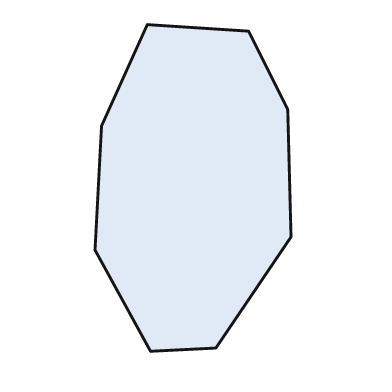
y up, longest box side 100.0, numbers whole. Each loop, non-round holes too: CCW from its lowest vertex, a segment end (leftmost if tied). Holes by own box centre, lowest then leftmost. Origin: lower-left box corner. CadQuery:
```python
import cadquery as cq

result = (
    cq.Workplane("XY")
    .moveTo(17.0, 0.0)
    .lineTo(37.0, 1.0)
    .lineTo(60.0, 35.0)
    .lineTo(59.0, 74.0)
    .lineTo(47.0, 98.0)
    .lineTo(16.0, 100.0)
    .lineTo(2.0, 69.0)
    .lineTo(0.0, 31.0)
    .close()
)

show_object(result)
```